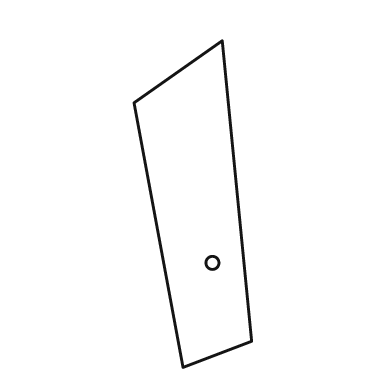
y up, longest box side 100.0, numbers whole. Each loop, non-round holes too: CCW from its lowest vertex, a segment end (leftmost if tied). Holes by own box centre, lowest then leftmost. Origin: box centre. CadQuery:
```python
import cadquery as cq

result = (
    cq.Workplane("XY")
    .moveTo(-3.0, -50.0)
    .lineTo(18.0, -42.0)
    .lineTo(9.0, 50.0)
    .lineTo(-18.0, 31.0)
    .close()
    .moveTo(6.0, -18.0)
    .circle(2.0)
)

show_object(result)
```